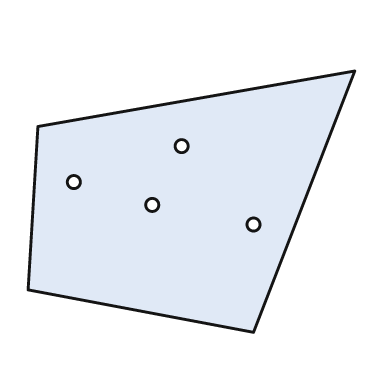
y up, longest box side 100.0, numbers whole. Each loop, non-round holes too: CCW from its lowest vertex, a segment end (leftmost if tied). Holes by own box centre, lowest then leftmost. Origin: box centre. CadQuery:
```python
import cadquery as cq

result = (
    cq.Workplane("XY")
    .moveTo(19.0, -40.0)
    .lineTo(50.0, 40.0)
    .lineTo(-47.0, 23.0)
    .lineTo(-50.0, -27.0)
    .close()
    .moveTo(19.0, -7.0)
    .circle(2.0)
    .moveTo(-12.0, -1.0)
    .circle(2.0)
    .moveTo(-36.0, 6.0)
    .circle(2.0)
    .moveTo(-3.0, 17.0)
    .circle(2.0)
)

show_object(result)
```